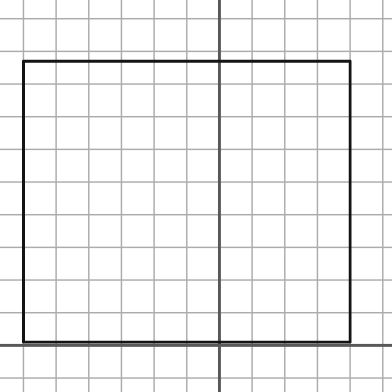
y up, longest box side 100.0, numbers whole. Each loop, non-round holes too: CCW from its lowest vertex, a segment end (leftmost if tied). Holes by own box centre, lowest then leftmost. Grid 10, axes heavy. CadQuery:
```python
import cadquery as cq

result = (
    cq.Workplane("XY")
    .moveTo(-60.0, 1.0)
    .lineTo(40.0, 1.0)
    .lineTo(40.0, 87.0)
    .lineTo(-60.0, 87.0)
    .close()
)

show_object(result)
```